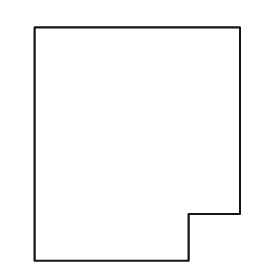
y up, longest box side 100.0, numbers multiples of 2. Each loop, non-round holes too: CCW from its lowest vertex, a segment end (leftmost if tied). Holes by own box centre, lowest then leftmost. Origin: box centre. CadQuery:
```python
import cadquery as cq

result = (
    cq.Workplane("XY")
    .moveTo(-44.0, -50.0)
    .lineTo(22.0, -50.0)
    .lineTo(22.0, -30.0)
    .lineTo(44.0, -30.0)
    .lineTo(44.0, 50.0)
    .lineTo(-44.0, 50.0)
    .close()
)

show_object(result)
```